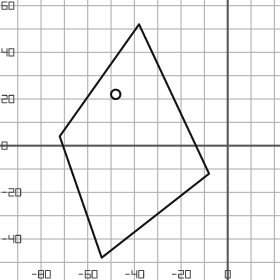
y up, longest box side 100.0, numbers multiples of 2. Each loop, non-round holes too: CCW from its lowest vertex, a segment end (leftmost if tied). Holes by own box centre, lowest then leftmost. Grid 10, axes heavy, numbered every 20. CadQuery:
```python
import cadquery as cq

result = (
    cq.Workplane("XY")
    .moveTo(-54.0, -48.0)
    .lineTo(-8.0, -12.0)
    .lineTo(-38.0, 52.0)
    .lineTo(-72.0, 4.0)
    .close()
    .moveTo(-48.0, 22.0)
    .circle(2.0)
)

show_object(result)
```